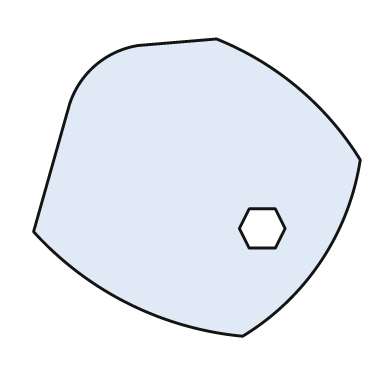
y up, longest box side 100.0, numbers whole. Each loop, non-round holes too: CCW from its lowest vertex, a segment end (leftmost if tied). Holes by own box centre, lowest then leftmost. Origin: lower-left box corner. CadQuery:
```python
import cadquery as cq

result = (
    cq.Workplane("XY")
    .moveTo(64.0, 0.0)
    .threePointArc((88.0, 23.0), (100.0, 54.0))
    .threePointArc((81.0, 76.0), (56.0, 91.0))
    .lineTo(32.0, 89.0)
    .threePointArc((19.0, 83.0), (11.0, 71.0))
    .lineTo(0.0, 32.0)
    .threePointArc((29.0, 10.0), (64.0, 0.0))
    .close()
    .moveTo(66.0, 27.0)
    .lineTo(74.0, 27.0)
    .lineTo(77.0, 33.0)
    .lineTo(74.0, 39.0)
    .lineTo(66.0, 39.0)
    .lineTo(63.0, 33.0)
    .close()
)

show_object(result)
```